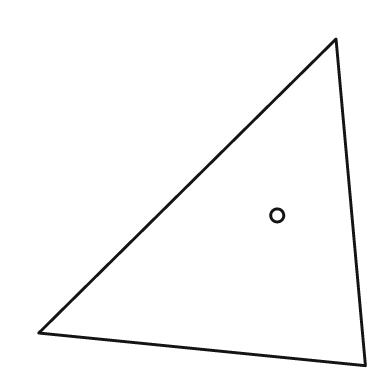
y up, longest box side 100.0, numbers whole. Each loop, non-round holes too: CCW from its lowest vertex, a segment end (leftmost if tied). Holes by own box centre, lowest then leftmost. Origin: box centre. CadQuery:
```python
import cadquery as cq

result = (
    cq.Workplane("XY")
    .moveTo(50.0, -50.0)
    .lineTo(41.0, 50.0)
    .lineTo(-50.0, -40.0)
    .close()
    .moveTo(23.0, -4.0)
    .circle(2.0)
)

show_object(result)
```